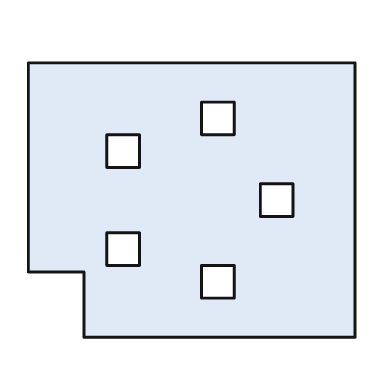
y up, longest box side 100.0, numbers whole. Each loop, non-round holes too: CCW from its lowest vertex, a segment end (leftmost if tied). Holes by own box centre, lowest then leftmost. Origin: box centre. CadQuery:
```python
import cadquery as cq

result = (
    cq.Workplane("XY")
    .moveTo(-33.0, -42.0)
    .lineTo(50.0, -42.0)
    .lineTo(50.0, 42.0)
    .lineTo(-50.0, 42.0)
    .lineTo(-50.0, -22.0)
    .lineTo(-33.0, -22.0)
    .close()
    .moveTo(3.0, -30.0)
    .lineTo(13.0, -30.0)
    .lineTo(13.0, -20.0)
    .lineTo(3.0, -20.0)
    .close()
    .moveTo(-26.0, -20.0)
    .lineTo(-16.0, -20.0)
    .lineTo(-16.0, -10.0)
    .lineTo(-26.0, -10.0)
    .close()
    .moveTo(21.0, -5.0)
    .lineTo(31.0, -5.0)
    .lineTo(31.0, 5.0)
    .lineTo(21.0, 5.0)
    .close()
    .moveTo(-26.0, 10.0)
    .lineTo(-16.0, 10.0)
    .lineTo(-16.0, 20.0)
    .lineTo(-26.0, 20.0)
    .close()
    .moveTo(3.0, 20.0)
    .lineTo(13.0, 20.0)
    .lineTo(13.0, 30.0)
    .lineTo(3.0, 30.0)
    .close()
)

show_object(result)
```